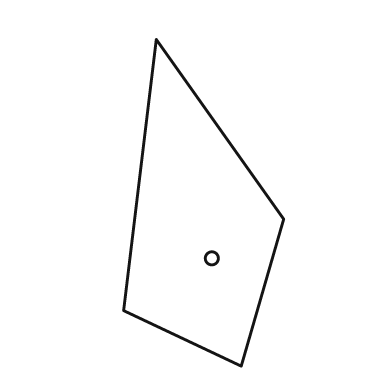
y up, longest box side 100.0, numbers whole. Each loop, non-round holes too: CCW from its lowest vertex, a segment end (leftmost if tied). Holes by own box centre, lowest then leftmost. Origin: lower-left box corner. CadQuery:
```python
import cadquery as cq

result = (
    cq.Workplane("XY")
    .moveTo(36.0, 0.0)
    .lineTo(49.0, 45.0)
    .lineTo(10.0, 100.0)
    .lineTo(0.0, 17.0)
    .close()
    .moveTo(27.0, 33.0)
    .circle(2.0)
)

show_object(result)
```